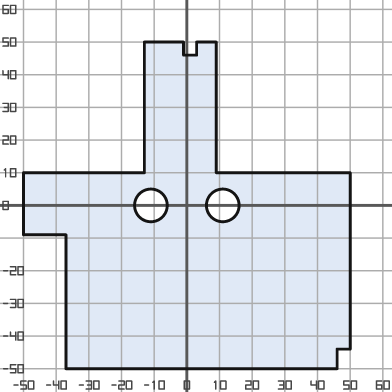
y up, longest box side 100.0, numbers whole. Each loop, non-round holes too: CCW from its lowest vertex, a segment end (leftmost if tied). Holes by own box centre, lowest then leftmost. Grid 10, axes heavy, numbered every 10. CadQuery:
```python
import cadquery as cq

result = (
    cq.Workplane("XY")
    .moveTo(-37.0, -50.0)
    .lineTo(46.0, -50.0)
    .lineTo(46.0, -44.0)
    .lineTo(50.0, -44.0)
    .lineTo(50.0, 10.0)
    .lineTo(9.0, 10.0)
    .lineTo(9.0, 50.0)
    .lineTo(3.0, 50.0)
    .lineTo(3.0, 46.0)
    .lineTo(-1.0, 46.0)
    .lineTo(-1.0, 50.0)
    .lineTo(-13.0, 50.0)
    .lineTo(-13.0, 10.0)
    .lineTo(-50.0, 10.0)
    .lineTo(-50.0, -9.0)
    .lineTo(-37.0, -9.0)
    .close()
    .moveTo(-11.0, 0.0)
    .circle(5.0)
    .moveTo(11.0, 0.0)
    .circle(5.0)
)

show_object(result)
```